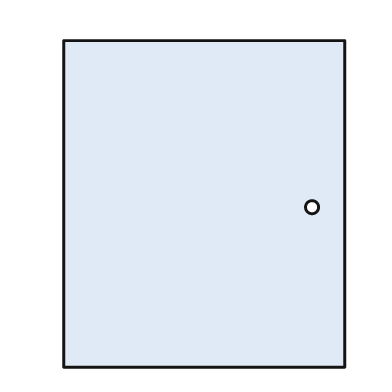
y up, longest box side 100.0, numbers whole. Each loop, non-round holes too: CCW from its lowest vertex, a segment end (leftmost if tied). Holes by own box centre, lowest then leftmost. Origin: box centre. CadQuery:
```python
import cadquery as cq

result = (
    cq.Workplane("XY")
    .moveTo(-43.0, -50.0)
    .lineTo(43.0, -50.0)
    .lineTo(43.0, 50.0)
    .lineTo(-43.0, 50.0)
    .close()
    .moveTo(33.0, -1.0)
    .circle(2.0)
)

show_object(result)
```